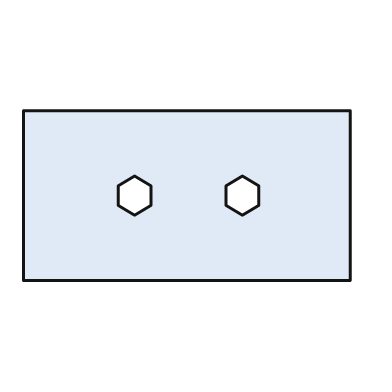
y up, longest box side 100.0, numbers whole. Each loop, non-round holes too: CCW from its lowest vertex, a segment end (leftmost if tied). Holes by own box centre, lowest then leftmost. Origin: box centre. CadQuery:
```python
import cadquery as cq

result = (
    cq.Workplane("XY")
    .moveTo(-50.0, -26.0)
    .lineTo(50.0, -26.0)
    .lineTo(50.0, 26.0)
    .lineTo(-50.0, 26.0)
    .close()
    .moveTo(-16.0, -6.0)
    .lineTo(-11.0, -3.0)
    .lineTo(-11.0, 3.0)
    .lineTo(-16.0, 6.0)
    .lineTo(-21.0, 3.0)
    .lineTo(-21.0, -3.0)
    .close()
    .moveTo(17.0, -6.0)
    .lineTo(22.0, -3.0)
    .lineTo(22.0, 3.0)
    .lineTo(17.0, 6.0)
    .lineTo(12.0, 3.0)
    .lineTo(12.0, -3.0)
    .close()
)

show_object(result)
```